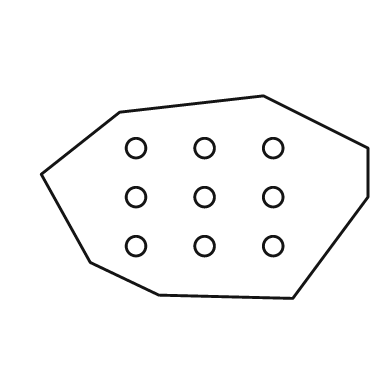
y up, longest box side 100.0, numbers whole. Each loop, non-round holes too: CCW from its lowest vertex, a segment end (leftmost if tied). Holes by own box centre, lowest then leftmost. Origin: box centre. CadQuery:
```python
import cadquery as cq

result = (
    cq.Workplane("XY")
    .moveTo(27.0, -31.0)
    .lineTo(50.0, 0.0)
    .lineTo(50.0, 15.0)
    .lineTo(18.0, 31.0)
    .lineTo(-26.0, 26.0)
    .lineTo(-50.0, 7.0)
    .lineTo(-35.0, -20.0)
    .lineTo(-14.0, -30.0)
    .close()
    .moveTo(-21.0, -15.0)
    .circle(3.0)
    .moveTo(0.0, -15.0)
    .circle(3.0)
    .moveTo(21.0, -15.0)
    .circle(3.0)
    .moveTo(-21.0, 0.0)
    .circle(3.0)
    .moveTo(0.0, 0.0)
    .circle(3.0)
    .moveTo(21.0, 0.0)
    .circle(3.0)
    .moveTo(-21.0, 15.0)
    .circle(3.0)
    .moveTo(0.0, 15.0)
    .circle(3.0)
    .moveTo(21.0, 15.0)
    .circle(3.0)
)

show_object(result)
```